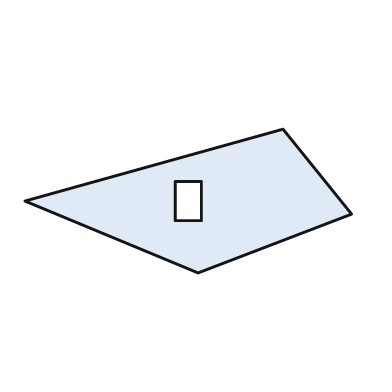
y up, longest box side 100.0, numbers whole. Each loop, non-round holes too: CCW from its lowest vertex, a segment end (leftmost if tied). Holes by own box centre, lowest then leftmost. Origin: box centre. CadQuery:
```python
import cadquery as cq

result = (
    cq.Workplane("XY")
    .moveTo(3.0, -22.0)
    .lineTo(50.0, -4.0)
    .lineTo(29.0, 22.0)
    .lineTo(-50.0, 0.0)
    .close()
    .moveTo(-4.0, -6.0)
    .lineTo(4.0, -6.0)
    .lineTo(4.0, 6.0)
    .lineTo(-4.0, 6.0)
    .close()
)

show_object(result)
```